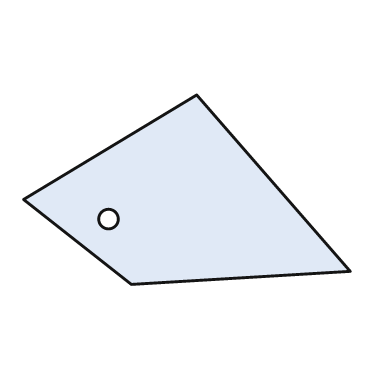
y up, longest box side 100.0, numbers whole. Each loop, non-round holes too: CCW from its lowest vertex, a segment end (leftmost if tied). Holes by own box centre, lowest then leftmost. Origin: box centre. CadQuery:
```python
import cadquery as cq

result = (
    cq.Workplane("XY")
    .moveTo(-17.0, -29.0)
    .lineTo(50.0, -25.0)
    .lineTo(3.0, 29.0)
    .lineTo(-50.0, -3.0)
    .close()
    .moveTo(-24.0, -9.0)
    .circle(3.0)
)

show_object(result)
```